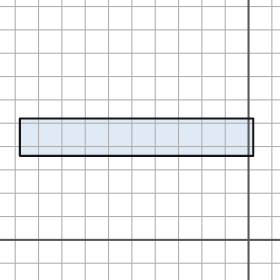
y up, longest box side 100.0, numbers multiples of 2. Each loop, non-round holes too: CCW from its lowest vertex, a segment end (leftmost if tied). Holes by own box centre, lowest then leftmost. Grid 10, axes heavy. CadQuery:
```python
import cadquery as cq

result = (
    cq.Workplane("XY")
    .moveTo(-98.0, 36.0)
    .lineTo(2.0, 36.0)
    .lineTo(2.0, 52.0)
    .lineTo(-98.0, 52.0)
    .close()
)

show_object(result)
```